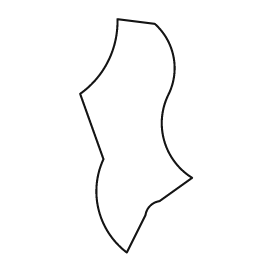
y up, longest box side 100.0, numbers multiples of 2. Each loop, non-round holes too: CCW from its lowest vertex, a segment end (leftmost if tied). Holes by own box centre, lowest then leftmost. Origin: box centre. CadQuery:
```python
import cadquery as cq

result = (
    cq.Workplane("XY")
    .moveTo(-4.0, -50.0)
    .lineTo(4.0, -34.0)
    .threePointArc((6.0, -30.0), (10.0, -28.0))
    .lineTo(24.0, -18.0)
    .threePointArc((12.0, -2.0), (14.0, 18.0))
    .threePointArc((16.0, 34.0), (8.0, 48.0))
    .lineTo(-8.0, 50.0)
    .threePointArc((-12.0, 32.0), (-24.0, 18.0))
    .lineTo(-14.0, -10.0)
    .threePointArc((-16.0, -32.0), (-4.0, -50.0))
    .close()
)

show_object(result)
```